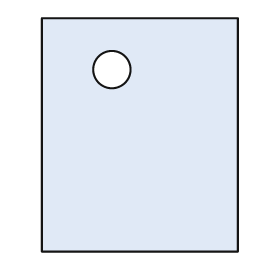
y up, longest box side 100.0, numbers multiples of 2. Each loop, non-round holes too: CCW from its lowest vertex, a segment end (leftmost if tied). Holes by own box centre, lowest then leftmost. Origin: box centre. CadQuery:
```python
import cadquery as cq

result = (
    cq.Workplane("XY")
    .moveTo(-42.0, -50.0)
    .lineTo(42.0, -50.0)
    .lineTo(42.0, 50.0)
    .lineTo(-42.0, 50.0)
    .close()
    .moveTo(-12.0, 28.0)
    .circle(8.0)
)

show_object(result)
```